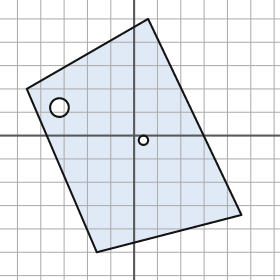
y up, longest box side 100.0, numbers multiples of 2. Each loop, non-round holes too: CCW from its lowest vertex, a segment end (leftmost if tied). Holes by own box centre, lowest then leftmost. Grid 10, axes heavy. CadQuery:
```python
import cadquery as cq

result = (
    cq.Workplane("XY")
    .moveTo(-16.0, -50.0)
    .lineTo(46.0, -34.0)
    .lineTo(6.0, 50.0)
    .lineTo(-46.0, 20.0)
    .close()
    .moveTo(4.0, -2.0)
    .circle(2.0)
    .moveTo(-32.0, 12.0)
    .circle(4.0)
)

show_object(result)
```